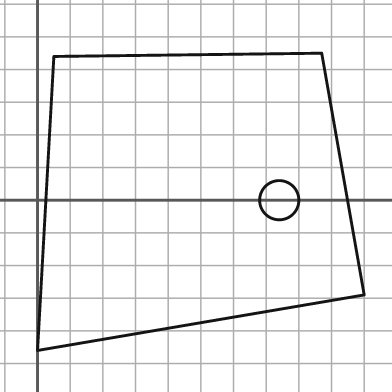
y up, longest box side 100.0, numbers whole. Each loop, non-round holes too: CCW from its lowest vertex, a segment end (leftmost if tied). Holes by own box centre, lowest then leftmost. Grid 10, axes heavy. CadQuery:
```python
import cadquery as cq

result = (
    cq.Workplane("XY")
    .moveTo(0.0, -46.0)
    .lineTo(100.0, -29.0)
    .lineTo(87.0, 45.0)
    .lineTo(5.0, 44.0)
    .close()
    .moveTo(74.0, 0.0)
    .circle(6.0)
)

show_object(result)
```